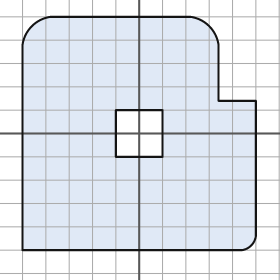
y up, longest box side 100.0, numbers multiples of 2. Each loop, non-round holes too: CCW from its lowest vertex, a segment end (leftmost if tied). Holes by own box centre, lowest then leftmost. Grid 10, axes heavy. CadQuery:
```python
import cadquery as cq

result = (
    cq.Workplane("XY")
    .moveTo(-50.0, -50.0)
    .lineTo(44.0, -50.0)
    .threePointArc((48.0, -48.0), (50.0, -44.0))
    .lineTo(50.0, 14.0)
    .lineTo(34.0, 14.0)
    .lineTo(34.0, 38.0)
    .threePointArc((30.0, 46.0), (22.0, 50.0))
    .lineTo(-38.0, 50.0)
    .threePointArc((-46.0, 46.0), (-50.0, 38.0))
    .close()
    .moveTo(-10.0, -10.0)
    .lineTo(10.0, -10.0)
    .lineTo(10.0, 10.0)
    .lineTo(-10.0, 10.0)
    .close()
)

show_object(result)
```